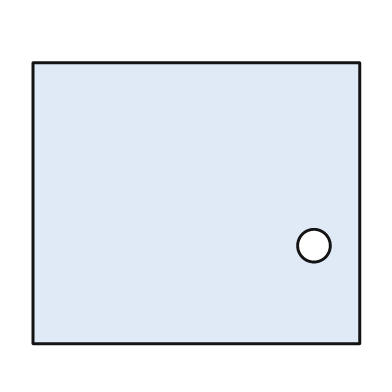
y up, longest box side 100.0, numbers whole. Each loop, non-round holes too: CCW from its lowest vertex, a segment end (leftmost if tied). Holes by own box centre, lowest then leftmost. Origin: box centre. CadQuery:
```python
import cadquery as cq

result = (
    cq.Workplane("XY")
    .moveTo(-50.0, -43.0)
    .lineTo(50.0, -43.0)
    .lineTo(50.0, 43.0)
    .lineTo(-50.0, 43.0)
    .close()
    .moveTo(36.0, -13.0)
    .circle(5.0)
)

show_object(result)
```